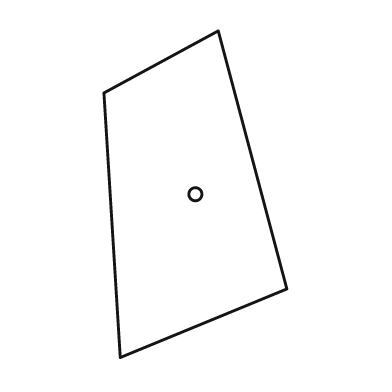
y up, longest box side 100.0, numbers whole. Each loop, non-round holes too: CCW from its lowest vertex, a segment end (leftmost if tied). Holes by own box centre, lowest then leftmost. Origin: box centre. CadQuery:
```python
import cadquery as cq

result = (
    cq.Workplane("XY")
    .moveTo(-23.0, -50.0)
    .lineTo(28.0, -29.0)
    .lineTo(7.0, 50.0)
    .lineTo(-28.0, 31.0)
    .close()
    .moveTo(0.0, 0.0)
    .circle(2.0)
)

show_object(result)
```